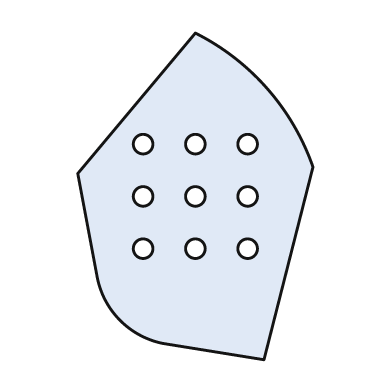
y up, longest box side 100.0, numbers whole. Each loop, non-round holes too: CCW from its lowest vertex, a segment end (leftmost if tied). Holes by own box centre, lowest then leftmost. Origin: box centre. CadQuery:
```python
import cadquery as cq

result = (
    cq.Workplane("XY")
    .moveTo(21.0, -50.0)
    .lineTo(36.0, 9.0)
    .threePointArc((22.0, 33.0), (0.0, 50.0))
    .lineTo(-36.0, 7.0)
    .lineTo(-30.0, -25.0)
    .threePointArc((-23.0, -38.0), (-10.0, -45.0))
    .close()
    .moveTo(-16.0, -16.0)
    .circle(3.0)
    .moveTo(0.0, -16.0)
    .circle(3.0)
    .moveTo(16.0, -16.0)
    .circle(3.0)
    .moveTo(-16.0, 0.0)
    .circle(3.0)
    .moveTo(0.0, 0.0)
    .circle(3.0)
    .moveTo(16.0, 0.0)
    .circle(3.0)
    .moveTo(-16.0, 16.0)
    .circle(3.0)
    .moveTo(0.0, 16.0)
    .circle(3.0)
    .moveTo(16.0, 16.0)
    .circle(3.0)
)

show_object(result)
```